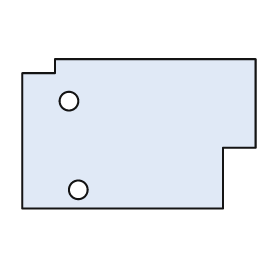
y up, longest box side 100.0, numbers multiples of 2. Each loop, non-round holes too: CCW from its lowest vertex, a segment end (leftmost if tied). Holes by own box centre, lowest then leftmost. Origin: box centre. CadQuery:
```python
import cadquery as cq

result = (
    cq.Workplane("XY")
    .moveTo(-50.0, -32.0)
    .lineTo(36.0, -32.0)
    .lineTo(36.0, -6.0)
    .lineTo(50.0, -6.0)
    .lineTo(50.0, 32.0)
    .lineTo(-36.0, 32.0)
    .lineTo(-36.0, 26.0)
    .lineTo(-50.0, 26.0)
    .close()
    .moveTo(-26.0, -24.0)
    .circle(4.0)
    .moveTo(-30.0, 14.0)
    .circle(4.0)
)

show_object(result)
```